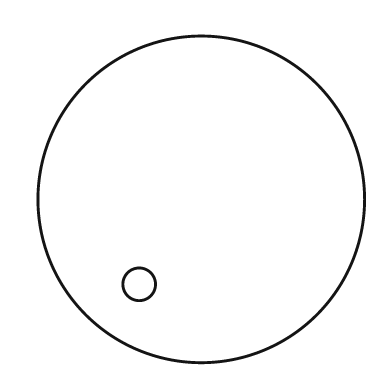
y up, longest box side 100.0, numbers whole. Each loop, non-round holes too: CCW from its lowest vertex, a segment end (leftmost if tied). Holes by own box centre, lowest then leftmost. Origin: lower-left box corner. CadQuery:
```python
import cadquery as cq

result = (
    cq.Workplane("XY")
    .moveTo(50.0, 50.0)
    .circle(50.0)
    .moveTo(31.0, 24.0)
    .circle(5.0)
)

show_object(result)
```